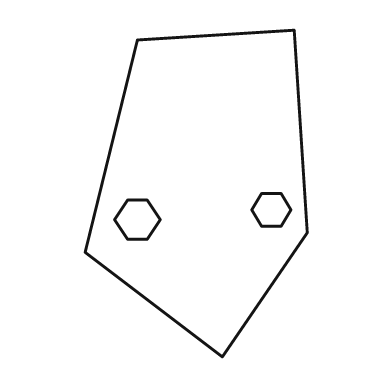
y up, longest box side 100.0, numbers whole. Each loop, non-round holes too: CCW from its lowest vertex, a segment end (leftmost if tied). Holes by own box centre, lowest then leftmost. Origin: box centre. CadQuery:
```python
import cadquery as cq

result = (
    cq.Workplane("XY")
    .moveTo(8.0, -50.0)
    .lineTo(34.0, -12.0)
    .lineTo(30.0, 50.0)
    .lineTo(-18.0, 47.0)
    .lineTo(-34.0, -18.0)
    .close()
    .moveTo(-21.0, -14.0)
    .lineTo(-15.0, -14.0)
    .lineTo(-11.0, -8.0)
    .lineTo(-15.0, -2.0)
    .lineTo(-21.0, -2.0)
    .lineTo(-25.0, -8.0)
    .close()
    .moveTo(20.0, -10.0)
    .lineTo(26.0, -10.0)
    .lineTo(29.0, -5.0)
    .lineTo(26.0, 0.0)
    .lineTo(20.0, 0.0)
    .lineTo(17.0, -5.0)
    .close()
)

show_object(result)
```